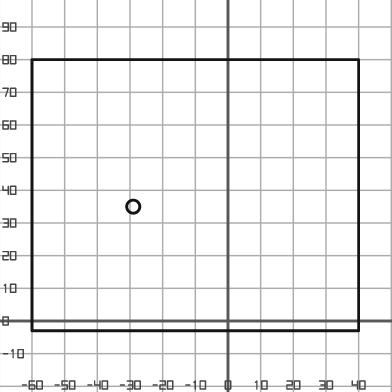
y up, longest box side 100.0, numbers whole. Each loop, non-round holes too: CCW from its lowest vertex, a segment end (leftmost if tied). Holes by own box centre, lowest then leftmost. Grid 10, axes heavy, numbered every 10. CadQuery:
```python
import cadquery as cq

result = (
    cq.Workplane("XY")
    .moveTo(-60.0, -3.0)
    .lineTo(40.0, -3.0)
    .lineTo(40.0, 80.0)
    .lineTo(-60.0, 80.0)
    .close()
    .moveTo(-29.0, 35.0)
    .circle(2.0)
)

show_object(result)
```